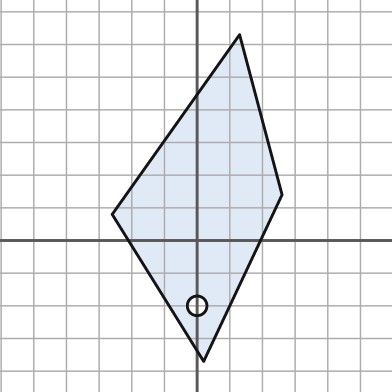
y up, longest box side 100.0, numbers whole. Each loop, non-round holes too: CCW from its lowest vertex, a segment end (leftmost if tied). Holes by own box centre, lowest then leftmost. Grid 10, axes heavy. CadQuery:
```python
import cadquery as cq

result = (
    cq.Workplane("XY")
    .moveTo(2.0, -37.0)
    .lineTo(26.0, 14.0)
    .lineTo(13.0, 63.0)
    .lineTo(-26.0, 8.0)
    .close()
    .moveTo(0.0, -20.0)
    .circle(3.0)
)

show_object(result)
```